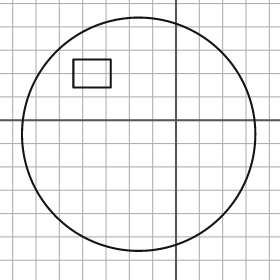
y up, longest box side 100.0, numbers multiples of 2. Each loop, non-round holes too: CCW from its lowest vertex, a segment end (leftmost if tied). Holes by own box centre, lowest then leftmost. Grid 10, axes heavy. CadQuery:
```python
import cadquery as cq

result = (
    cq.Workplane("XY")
    .moveTo(-16.0, -6.0)
    .circle(50.0)
    .moveTo(-44.0, 14.0)
    .lineTo(-28.0, 14.0)
    .lineTo(-28.0, 26.0)
    .lineTo(-44.0, 26.0)
    .close()
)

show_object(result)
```